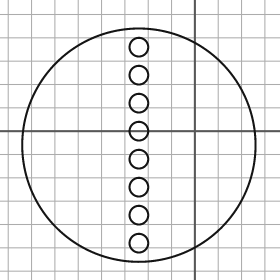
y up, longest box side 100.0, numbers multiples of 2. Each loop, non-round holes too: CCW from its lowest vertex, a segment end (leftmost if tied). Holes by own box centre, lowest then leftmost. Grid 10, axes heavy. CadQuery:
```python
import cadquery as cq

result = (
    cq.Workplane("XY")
    .moveTo(-24.0, -6.0)
    .circle(50.0)
    .moveTo(-24.0, -48.0)
    .circle(4.0)
    .moveTo(-24.0, -36.0)
    .circle(4.0)
    .moveTo(-24.0, -24.0)
    .circle(4.0)
    .moveTo(-24.0, -12.0)
    .circle(4.0)
    .moveTo(-24.0, 0.0)
    .circle(4.0)
    .moveTo(-24.0, 12.0)
    .circle(4.0)
    .moveTo(-24.0, 24.0)
    .circle(4.0)
    .moveTo(-24.0, 36.0)
    .circle(4.0)
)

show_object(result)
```